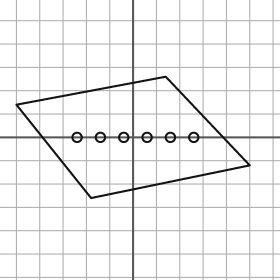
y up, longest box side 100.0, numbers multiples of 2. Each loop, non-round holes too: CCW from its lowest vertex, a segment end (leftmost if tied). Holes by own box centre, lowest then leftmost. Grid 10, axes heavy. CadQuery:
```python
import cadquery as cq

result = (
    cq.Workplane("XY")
    .moveTo(-18.0, -26.0)
    .lineTo(50.0, -12.0)
    .lineTo(14.0, 26.0)
    .lineTo(-50.0, 14.0)
    .close()
    .moveTo(-24.0, 0.0)
    .circle(2.0)
    .moveTo(-14.0, 0.0)
    .circle(2.0)
    .moveTo(-4.0, 0.0)
    .circle(2.0)
    .moveTo(6.0, 0.0)
    .circle(2.0)
    .moveTo(16.0, 0.0)
    .circle(2.0)
    .moveTo(26.0, 0.0)
    .circle(2.0)
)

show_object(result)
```